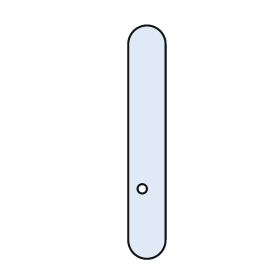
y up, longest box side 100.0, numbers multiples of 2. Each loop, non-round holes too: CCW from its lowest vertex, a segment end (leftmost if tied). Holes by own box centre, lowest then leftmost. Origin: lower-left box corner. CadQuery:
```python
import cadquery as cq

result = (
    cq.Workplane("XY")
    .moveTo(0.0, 8.0)
    .threePointArc((8.0, 0.0), (16.0, 8.0))
    .lineTo(16.0, 92.0)
    .threePointArc((8.0, 100.0), (0.0, 92.0))
    .close()
    .moveTo(6.0, 30.0)
    .circle(2.0)
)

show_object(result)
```